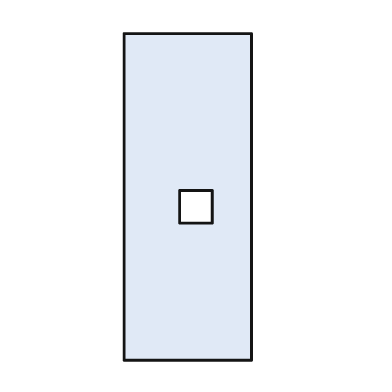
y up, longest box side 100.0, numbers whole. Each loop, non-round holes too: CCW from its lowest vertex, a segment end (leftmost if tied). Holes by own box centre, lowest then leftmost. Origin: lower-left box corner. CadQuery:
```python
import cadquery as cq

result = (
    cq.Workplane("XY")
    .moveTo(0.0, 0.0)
    .lineTo(39.0, 0.0)
    .lineTo(39.0, 100.0)
    .lineTo(0.0, 100.0)
    .close()
    .moveTo(17.0, 42.0)
    .lineTo(27.0, 42.0)
    .lineTo(27.0, 52.0)
    .lineTo(17.0, 52.0)
    .close()
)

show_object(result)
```